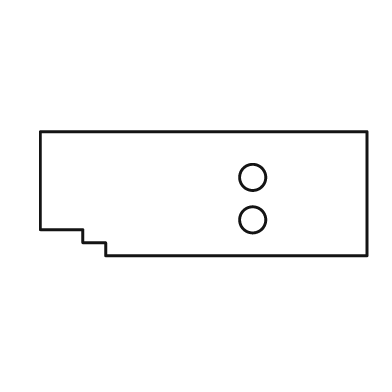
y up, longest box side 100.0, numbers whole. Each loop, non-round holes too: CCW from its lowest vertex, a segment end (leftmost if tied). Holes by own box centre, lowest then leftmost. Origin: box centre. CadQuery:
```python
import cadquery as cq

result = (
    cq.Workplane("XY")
    .moveTo(-30.0, -19.0)
    .lineTo(50.0, -19.0)
    .lineTo(50.0, 19.0)
    .lineTo(-50.0, 19.0)
    .lineTo(-50.0, -11.0)
    .lineTo(-37.0, -11.0)
    .lineTo(-37.0, -15.0)
    .lineTo(-30.0, -15.0)
    .close()
    .moveTo(15.0, -8.0)
    .circle(4.0)
    .moveTo(15.0, 5.0)
    .circle(4.0)
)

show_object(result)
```